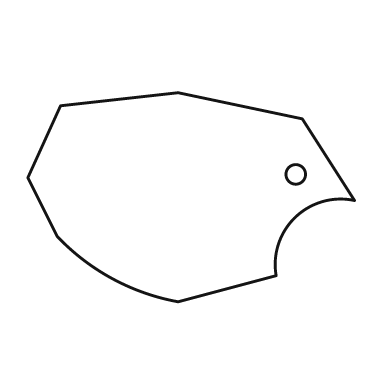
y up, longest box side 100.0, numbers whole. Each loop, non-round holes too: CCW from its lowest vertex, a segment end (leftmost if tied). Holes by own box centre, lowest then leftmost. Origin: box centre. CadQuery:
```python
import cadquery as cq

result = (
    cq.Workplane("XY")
    .moveTo(-4.0, -32.0)
    .lineTo(26.0, -24.0)
    .threePointArc((32.0, -6.0), (50.0, -1.0))
    .lineTo(34.0, 24.0)
    .lineTo(-4.0, 32.0)
    .lineTo(-40.0, 28.0)
    .lineTo(-50.0, 6.0)
    .lineTo(-41.0, -12.0)
    .threePointArc((-24.0, -25.0), (-4.0, -32.0))
    .close()
    .moveTo(32.0, 7.0)
    .circle(3.0)
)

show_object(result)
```